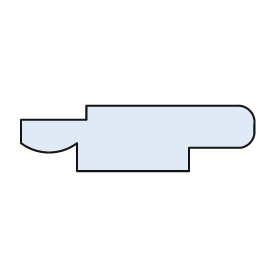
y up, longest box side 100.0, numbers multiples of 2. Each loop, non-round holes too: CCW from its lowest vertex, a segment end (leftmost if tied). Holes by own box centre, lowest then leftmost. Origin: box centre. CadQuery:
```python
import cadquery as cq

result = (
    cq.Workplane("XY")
    .moveTo(-26.0, -14.0)
    .lineTo(22.0, -14.0)
    .lineTo(22.0, -4.0)
    .lineTo(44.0, -4.0)
    .threePointArc((48.0, -2.0), (50.0, 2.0))
    .lineTo(50.0, 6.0)
    .threePointArc((48.0, 12.0), (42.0, 14.0))
    .lineTo(-22.0, 14.0)
    .lineTo(-22.0, 8.0)
    .lineTo(-50.0, 8.0)
    .lineTo(-50.0, -2.0)
    .threePointArc((-38.0, -6.0), (-26.0, -2.0))
    .close()
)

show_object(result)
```